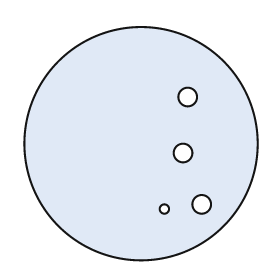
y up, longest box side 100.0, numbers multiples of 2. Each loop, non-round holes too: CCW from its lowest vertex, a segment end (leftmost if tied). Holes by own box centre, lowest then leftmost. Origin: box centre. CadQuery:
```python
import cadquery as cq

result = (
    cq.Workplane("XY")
    .moveTo(0.0, 0.0)
    .circle(50.0)
    .moveTo(10.0, -28.0)
    .circle(2.0)
    .moveTo(26.0, -26.0)
    .circle(4.0)
    .moveTo(18.0, -4.0)
    .circle(4.0)
    .moveTo(20.0, 20.0)
    .circle(4.0)
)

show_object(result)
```